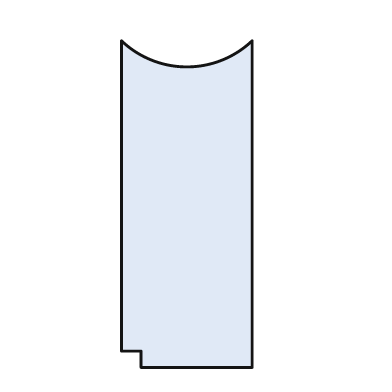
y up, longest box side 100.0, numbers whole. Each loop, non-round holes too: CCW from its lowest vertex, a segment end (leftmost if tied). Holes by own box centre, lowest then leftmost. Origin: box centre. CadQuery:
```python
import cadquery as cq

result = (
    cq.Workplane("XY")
    .moveTo(-14.0, -50.0)
    .lineTo(20.0, -50.0)
    .lineTo(20.0, 50.0)
    .threePointArc((0.0, 42.0), (-20.0, 50.0))
    .lineTo(-20.0, -45.0)
    .lineTo(-14.0, -45.0)
    .close()
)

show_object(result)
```